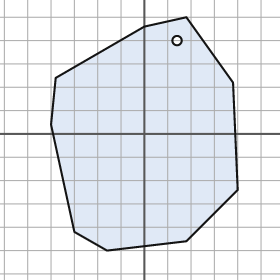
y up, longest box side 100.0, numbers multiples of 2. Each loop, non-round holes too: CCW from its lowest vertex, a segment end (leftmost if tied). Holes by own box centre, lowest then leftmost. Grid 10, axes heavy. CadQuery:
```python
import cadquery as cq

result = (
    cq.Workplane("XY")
    .moveTo(-16.0, -50.0)
    .lineTo(18.0, -46.0)
    .lineTo(40.0, -24.0)
    .lineTo(38.0, 22.0)
    .lineTo(18.0, 50.0)
    .lineTo(0.0, 46.0)
    .lineTo(-38.0, 24.0)
    .lineTo(-40.0, 4.0)
    .lineTo(-30.0, -42.0)
    .close()
    .moveTo(14.0, 40.0)
    .circle(2.0)
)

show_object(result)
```